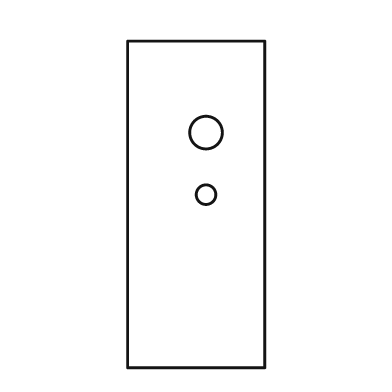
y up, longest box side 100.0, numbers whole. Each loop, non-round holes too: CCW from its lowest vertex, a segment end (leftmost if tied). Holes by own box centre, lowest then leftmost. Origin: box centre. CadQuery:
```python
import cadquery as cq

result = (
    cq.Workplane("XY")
    .moveTo(-21.0, -50.0)
    .lineTo(21.0, -50.0)
    .lineTo(21.0, 50.0)
    .lineTo(-21.0, 50.0)
    .close()
    .moveTo(3.0, 3.0)
    .circle(3.0)
    .moveTo(3.0, 22.0)
    .circle(5.0)
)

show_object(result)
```